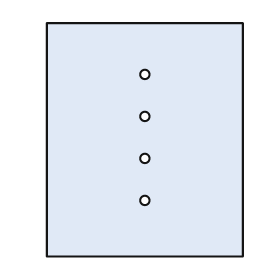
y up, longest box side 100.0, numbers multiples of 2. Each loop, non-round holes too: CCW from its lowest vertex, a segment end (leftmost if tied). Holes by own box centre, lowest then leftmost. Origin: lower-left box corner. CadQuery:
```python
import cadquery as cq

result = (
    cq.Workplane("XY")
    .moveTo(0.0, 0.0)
    .lineTo(84.0, 0.0)
    .lineTo(84.0, 100.0)
    .lineTo(0.0, 100.0)
    .close()
    .moveTo(42.0, 24.0)
    .circle(2.0)
    .moveTo(42.0, 42.0)
    .circle(2.0)
    .moveTo(42.0, 60.0)
    .circle(2.0)
    .moveTo(42.0, 78.0)
    .circle(2.0)
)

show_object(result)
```